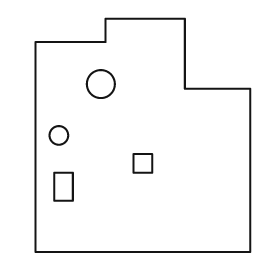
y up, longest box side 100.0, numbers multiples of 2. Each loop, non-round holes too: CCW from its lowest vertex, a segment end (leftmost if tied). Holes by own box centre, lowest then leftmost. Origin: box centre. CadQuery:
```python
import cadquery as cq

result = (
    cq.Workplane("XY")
    .moveTo(-46.0, -50.0)
    .lineTo(46.0, -50.0)
    .lineTo(46.0, 20.0)
    .lineTo(18.0, 20.0)
    .lineTo(18.0, 50.0)
    .lineTo(-16.0, 50.0)
    .lineTo(-16.0, 40.0)
    .lineTo(-46.0, 40.0)
    .close()
    .moveTo(-38.0, -28.0)
    .lineTo(-30.0, -28.0)
    .lineTo(-30.0, -16.0)
    .lineTo(-38.0, -16.0)
    .close()
    .moveTo(-4.0, -16.0)
    .lineTo(4.0, -16.0)
    .lineTo(4.0, -8.0)
    .lineTo(-4.0, -8.0)
    .close()
    .moveTo(-36.0, 0.0)
    .circle(4.0)
    .moveTo(-18.0, 22.0)
    .circle(6.0)
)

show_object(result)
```